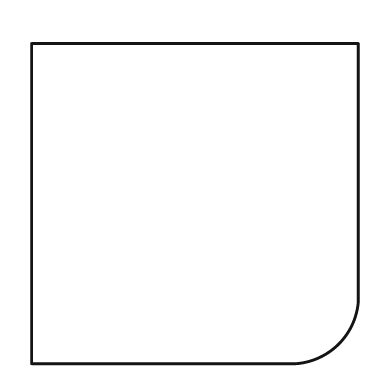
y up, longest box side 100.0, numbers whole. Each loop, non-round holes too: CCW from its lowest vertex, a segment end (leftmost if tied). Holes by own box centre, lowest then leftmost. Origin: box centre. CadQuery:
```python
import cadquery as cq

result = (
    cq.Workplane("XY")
    .moveTo(-50.0, -49.0)
    .lineTo(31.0, -49.0)
    .threePointArc((44.0, -43.0), (50.0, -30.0))
    .lineTo(50.0, 49.0)
    .lineTo(-50.0, 49.0)
    .close()
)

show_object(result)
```